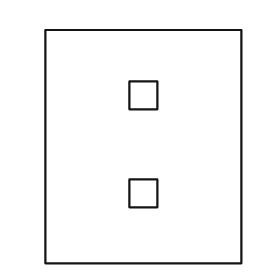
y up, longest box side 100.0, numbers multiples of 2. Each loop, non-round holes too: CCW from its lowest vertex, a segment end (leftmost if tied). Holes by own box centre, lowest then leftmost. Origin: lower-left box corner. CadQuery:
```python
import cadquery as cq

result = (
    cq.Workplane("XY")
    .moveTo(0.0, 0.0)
    .lineTo(84.0, 0.0)
    .lineTo(84.0, 100.0)
    .lineTo(0.0, 100.0)
    .close()
    .moveTo(36.0, 24.0)
    .lineTo(48.0, 24.0)
    .lineTo(48.0, 36.0)
    .lineTo(36.0, 36.0)
    .close()
    .moveTo(36.0, 66.0)
    .lineTo(48.0, 66.0)
    .lineTo(48.0, 78.0)
    .lineTo(36.0, 78.0)
    .close()
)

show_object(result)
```